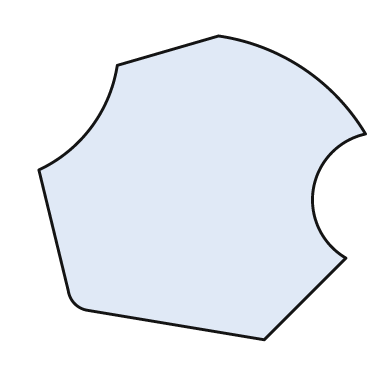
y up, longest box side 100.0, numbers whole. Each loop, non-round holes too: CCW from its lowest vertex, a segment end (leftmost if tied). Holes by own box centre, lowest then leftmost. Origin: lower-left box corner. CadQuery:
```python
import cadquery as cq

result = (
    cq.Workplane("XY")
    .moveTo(69.0, 0.0)
    .lineTo(94.0, 25.0)
    .threePointArc((84.0, 46.0), (100.0, 63.0))
    .threePointArc((81.0, 83.0), (55.0, 93.0))
    .lineTo(24.0, 84.0)
    .threePointArc((16.0, 65.0), (0.0, 52.0))
    .lineTo(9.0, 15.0)
    .threePointArc((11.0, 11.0), (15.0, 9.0))
    .close()
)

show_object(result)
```